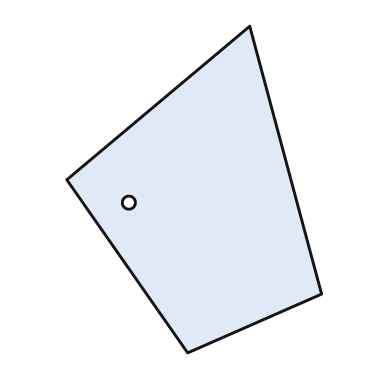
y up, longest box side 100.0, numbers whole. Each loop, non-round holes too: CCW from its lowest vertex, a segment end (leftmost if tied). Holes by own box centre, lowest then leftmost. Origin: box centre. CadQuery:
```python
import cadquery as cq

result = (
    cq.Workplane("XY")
    .moveTo(-2.0, -50.0)
    .lineTo(39.0, -32.0)
    .lineTo(17.0, 50.0)
    .lineTo(-39.0, 3.0)
    .close()
    .moveTo(-20.0, -4.0)
    .circle(2.0)
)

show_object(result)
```